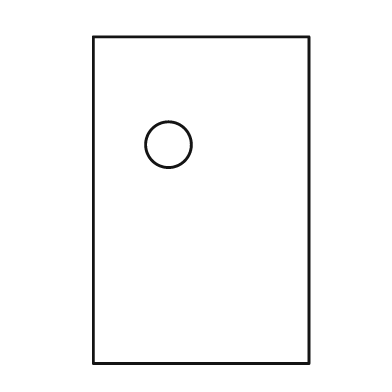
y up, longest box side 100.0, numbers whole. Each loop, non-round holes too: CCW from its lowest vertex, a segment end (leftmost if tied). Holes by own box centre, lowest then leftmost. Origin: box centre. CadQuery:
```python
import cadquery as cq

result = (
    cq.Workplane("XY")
    .moveTo(-33.0, -50.0)
    .lineTo(33.0, -50.0)
    .lineTo(33.0, 50.0)
    .lineTo(-33.0, 50.0)
    .close()
    .moveTo(-10.0, 17.0)
    .circle(7.0)
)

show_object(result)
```